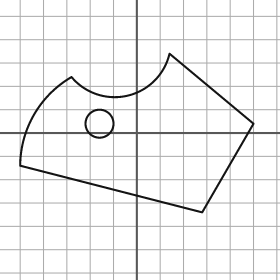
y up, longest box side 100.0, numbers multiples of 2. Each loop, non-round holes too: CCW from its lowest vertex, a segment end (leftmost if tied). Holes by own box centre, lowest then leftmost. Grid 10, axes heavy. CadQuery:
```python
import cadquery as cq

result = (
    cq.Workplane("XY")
    .moveTo(28.0, -34.0)
    .lineTo(50.0, 4.0)
    .lineTo(14.0, 34.0)
    .threePointArc((-4.0, 16.0), (-28.0, 24.0))
    .threePointArc((-44.0, 8.0), (-50.0, -14.0))
    .close()
    .moveTo(-16.0, 4.0)
    .circle(6.0)
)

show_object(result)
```